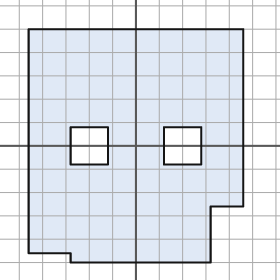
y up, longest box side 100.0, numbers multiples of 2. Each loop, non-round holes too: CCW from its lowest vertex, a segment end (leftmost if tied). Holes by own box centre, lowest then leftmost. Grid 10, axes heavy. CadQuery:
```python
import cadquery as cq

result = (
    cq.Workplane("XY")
    .moveTo(-28.0, -50.0)
    .lineTo(32.0, -50.0)
    .lineTo(32.0, -26.0)
    .lineTo(46.0, -26.0)
    .lineTo(46.0, 50.0)
    .lineTo(-46.0, 50.0)
    .lineTo(-46.0, -46.0)
    .lineTo(-28.0, -46.0)
    .close()
    .moveTo(-28.0, -8.0)
    .lineTo(-12.0, -8.0)
    .lineTo(-12.0, 8.0)
    .lineTo(-28.0, 8.0)
    .close()
    .moveTo(12.0, -8.0)
    .lineTo(28.0, -8.0)
    .lineTo(28.0, 8.0)
    .lineTo(12.0, 8.0)
    .close()
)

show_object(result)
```